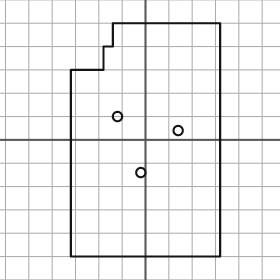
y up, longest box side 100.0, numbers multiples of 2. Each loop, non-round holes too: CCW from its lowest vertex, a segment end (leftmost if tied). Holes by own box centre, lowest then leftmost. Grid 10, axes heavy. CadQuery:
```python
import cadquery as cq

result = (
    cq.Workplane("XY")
    .moveTo(-32.0, -50.0)
    .lineTo(32.0, -50.0)
    .lineTo(32.0, 50.0)
    .lineTo(-14.0, 50.0)
    .lineTo(-14.0, 40.0)
    .lineTo(-18.0, 40.0)
    .lineTo(-18.0, 30.0)
    .lineTo(-32.0, 30.0)
    .close()
    .moveTo(-2.0, -14.0)
    .circle(2.0)
    .moveTo(14.0, 4.0)
    .circle(2.0)
    .moveTo(-12.0, 10.0)
    .circle(2.0)
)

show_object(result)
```